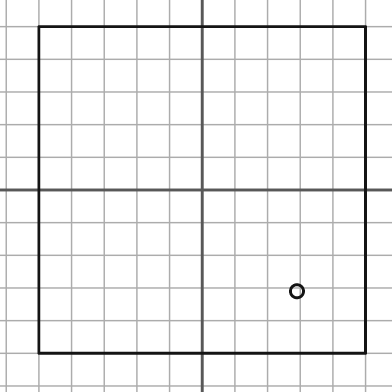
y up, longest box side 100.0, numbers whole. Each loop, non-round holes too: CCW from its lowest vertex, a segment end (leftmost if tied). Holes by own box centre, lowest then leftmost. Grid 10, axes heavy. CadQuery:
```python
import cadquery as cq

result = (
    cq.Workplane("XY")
    .moveTo(-50.0, -50.0)
    .lineTo(50.0, -50.0)
    .lineTo(50.0, 50.0)
    .lineTo(-50.0, 50.0)
    .close()
    .moveTo(29.0, -31.0)
    .circle(2.0)
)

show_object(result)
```